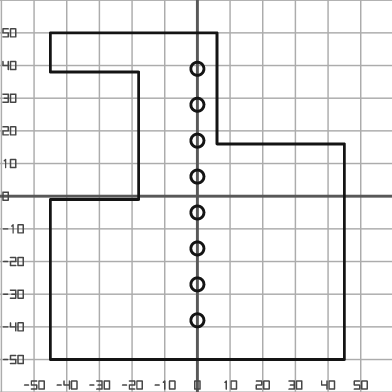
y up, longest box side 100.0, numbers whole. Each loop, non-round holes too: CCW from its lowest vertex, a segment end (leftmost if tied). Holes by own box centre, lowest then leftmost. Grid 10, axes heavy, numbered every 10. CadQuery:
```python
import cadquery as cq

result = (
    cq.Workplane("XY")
    .moveTo(-45.0, -50.0)
    .lineTo(45.0, -50.0)
    .lineTo(45.0, 16.0)
    .lineTo(6.0, 16.0)
    .lineTo(6.0, 50.0)
    .lineTo(-45.0, 50.0)
    .lineTo(-45.0, 38.0)
    .lineTo(-18.0, 38.0)
    .lineTo(-18.0, -1.0)
    .lineTo(-45.0, -1.0)
    .close()
    .moveTo(0.0, -38.0)
    .circle(2.0)
    .moveTo(0.0, -27.0)
    .circle(2.0)
    .moveTo(0.0, -16.0)
    .circle(2.0)
    .moveTo(0.0, -5.0)
    .circle(2.0)
    .moveTo(0.0, 6.0)
    .circle(2.0)
    .moveTo(0.0, 17.0)
    .circle(2.0)
    .moveTo(0.0, 28.0)
    .circle(2.0)
    .moveTo(0.0, 39.0)
    .circle(2.0)
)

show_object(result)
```